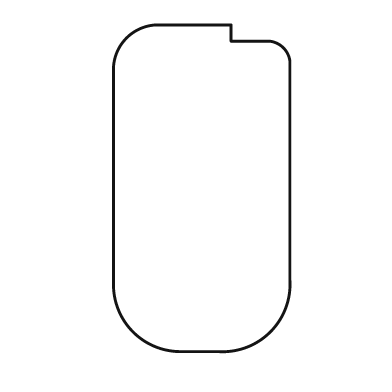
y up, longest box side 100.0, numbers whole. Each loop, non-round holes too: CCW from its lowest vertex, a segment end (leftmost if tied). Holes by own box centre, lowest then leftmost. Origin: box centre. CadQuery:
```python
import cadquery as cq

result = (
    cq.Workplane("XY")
    .moveTo(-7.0, -50.0)
    .lineTo(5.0, -50.0)
    .threePointArc((21.0, -44.0), (27.0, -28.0))
    .lineTo(27.0, 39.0)
    .threePointArc((25.0, 43.0), (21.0, 45.0))
    .lineTo(9.0, 45.0)
    .lineTo(9.0, 50.0)
    .lineTo(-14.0, 50.0)
    .threePointArc((-23.0, 46.0), (-27.0, 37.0))
    .lineTo(-27.0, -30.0)
    .threePointArc((-21.0, -44.0), (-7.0, -50.0))
    .close()
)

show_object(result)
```